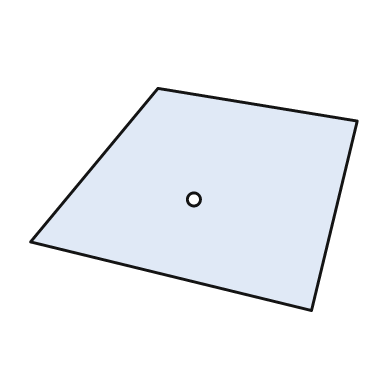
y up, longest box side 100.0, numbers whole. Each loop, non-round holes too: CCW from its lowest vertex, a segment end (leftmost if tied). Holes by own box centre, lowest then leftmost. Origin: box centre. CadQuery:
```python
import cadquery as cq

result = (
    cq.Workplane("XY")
    .moveTo(36.0, -34.0)
    .lineTo(50.0, 24.0)
    .lineTo(-11.0, 34.0)
    .lineTo(-50.0, -13.0)
    .close()
    .moveTo(0.0, 0.0)
    .circle(2.0)
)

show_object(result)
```